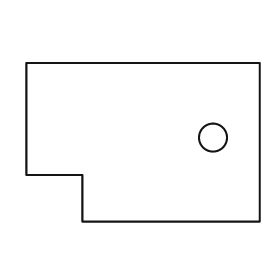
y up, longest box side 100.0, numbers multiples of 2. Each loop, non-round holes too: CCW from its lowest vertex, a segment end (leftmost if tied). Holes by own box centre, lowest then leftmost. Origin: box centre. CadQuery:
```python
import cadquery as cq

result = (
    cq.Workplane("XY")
    .moveTo(-26.0, -34.0)
    .lineTo(50.0, -34.0)
    .lineTo(50.0, 34.0)
    .lineTo(-50.0, 34.0)
    .lineTo(-50.0, -14.0)
    .lineTo(-26.0, -14.0)
    .close()
    .moveTo(30.0, 2.0)
    .circle(6.0)
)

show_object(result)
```